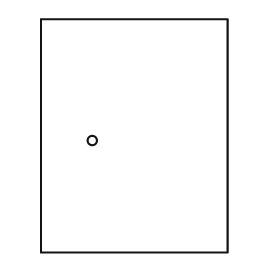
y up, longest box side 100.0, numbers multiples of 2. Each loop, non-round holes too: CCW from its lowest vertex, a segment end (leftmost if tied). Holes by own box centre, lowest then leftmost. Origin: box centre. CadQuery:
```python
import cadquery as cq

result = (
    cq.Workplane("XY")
    .moveTo(-40.0, -50.0)
    .lineTo(40.0, -50.0)
    .lineTo(40.0, 50.0)
    .lineTo(-40.0, 50.0)
    .close()
    .moveTo(-18.0, -2.0)
    .circle(2.0)
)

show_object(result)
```